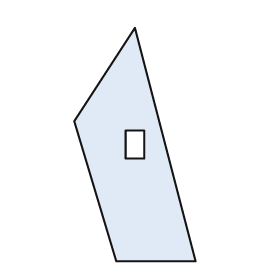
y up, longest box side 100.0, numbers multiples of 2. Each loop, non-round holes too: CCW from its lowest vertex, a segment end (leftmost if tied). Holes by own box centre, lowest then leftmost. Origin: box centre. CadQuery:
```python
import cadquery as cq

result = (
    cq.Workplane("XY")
    .moveTo(-8.0, -50.0)
    .lineTo(26.0, -50.0)
    .lineTo(0.0, 50.0)
    .lineTo(-26.0, 10.0)
    .close()
    .moveTo(-4.0, -6.0)
    .lineTo(4.0, -6.0)
    .lineTo(4.0, 6.0)
    .lineTo(-4.0, 6.0)
    .close()
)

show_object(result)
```